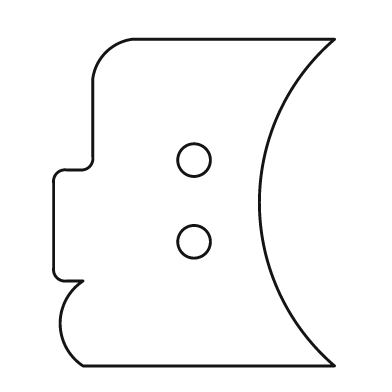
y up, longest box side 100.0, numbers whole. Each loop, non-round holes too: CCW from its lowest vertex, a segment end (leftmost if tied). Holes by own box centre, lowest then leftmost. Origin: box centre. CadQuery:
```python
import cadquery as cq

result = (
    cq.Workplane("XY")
    .moveTo(-34.0, -50.0)
    .lineTo(43.0, -50.0)
    .threePointArc((20.0, 0.0), (43.0, 50.0))
    .lineTo(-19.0, 50.0)
    .threePointArc((-27.0, 46.0), (-31.0, 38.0))
    .lineTo(-31.0, 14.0)
    .threePointArc((-32.0, 11.0), (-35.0, 10.0))
    .lineTo(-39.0, 10.0)
    .threePointArc((-42.0, 9.0), (-43.0, 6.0))
    .lineTo(-43.0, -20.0)
    .threePointArc((-42.0, -23.0), (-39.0, -24.0))
    .lineTo(-34.0, -24.0)
    .threePointArc((-41.0, -37.0), (-34.0, -50.0))
    .close()
    .moveTo(0.0, -12.0)
    .circle(5.0)
    .moveTo(0.0, 13.0)
    .circle(5.0)
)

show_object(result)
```